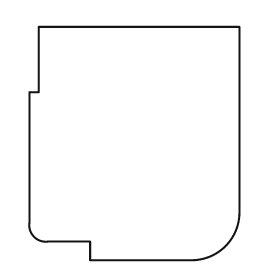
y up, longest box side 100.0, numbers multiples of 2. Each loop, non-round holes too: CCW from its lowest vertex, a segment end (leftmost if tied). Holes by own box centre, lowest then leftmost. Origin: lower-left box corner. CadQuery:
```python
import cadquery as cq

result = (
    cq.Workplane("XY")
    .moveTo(26.0, 0.0)
    .lineTo(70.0, 0.0)
    .threePointArc((84.0, 6.0), (90.0, 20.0))
    .lineTo(90.0, 100.0)
    .lineTo(4.0, 100.0)
    .lineTo(4.0, 72.0)
    .lineTo(0.0, 72.0)
    .lineTo(0.0, 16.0)
    .threePointArc((2.0, 10.0), (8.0, 8.0))
    .lineTo(26.0, 8.0)
    .close()
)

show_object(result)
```